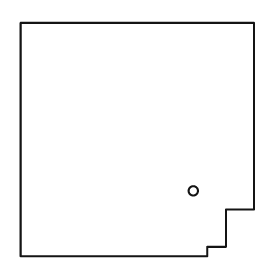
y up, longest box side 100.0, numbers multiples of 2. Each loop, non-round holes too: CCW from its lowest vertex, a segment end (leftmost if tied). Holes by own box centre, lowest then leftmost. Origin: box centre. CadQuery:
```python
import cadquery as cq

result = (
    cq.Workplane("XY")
    .moveTo(-50.0, -50.0)
    .lineTo(30.0, -50.0)
    .lineTo(30.0, -46.0)
    .lineTo(38.0, -46.0)
    .lineTo(38.0, -30.0)
    .lineTo(50.0, -30.0)
    .lineTo(50.0, 50.0)
    .lineTo(-50.0, 50.0)
    .close()
    .moveTo(24.0, -22.0)
    .circle(2.0)
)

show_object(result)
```